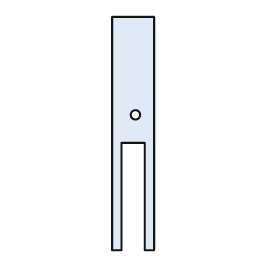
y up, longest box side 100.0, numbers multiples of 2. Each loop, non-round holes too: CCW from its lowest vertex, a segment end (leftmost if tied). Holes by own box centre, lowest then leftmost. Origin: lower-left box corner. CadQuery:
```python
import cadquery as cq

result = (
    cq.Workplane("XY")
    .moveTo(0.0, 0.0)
    .lineTo(4.0, 0.0)
    .lineTo(4.0, 46.0)
    .lineTo(14.0, 46.0)
    .lineTo(14.0, 0.0)
    .lineTo(18.0, 0.0)
    .lineTo(18.0, 100.0)
    .lineTo(0.0, 100.0)
    .close()
    .moveTo(10.0, 58.0)
    .circle(2.0)
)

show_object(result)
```